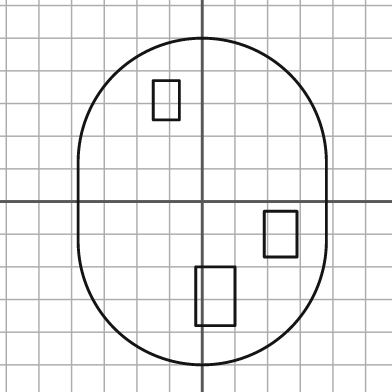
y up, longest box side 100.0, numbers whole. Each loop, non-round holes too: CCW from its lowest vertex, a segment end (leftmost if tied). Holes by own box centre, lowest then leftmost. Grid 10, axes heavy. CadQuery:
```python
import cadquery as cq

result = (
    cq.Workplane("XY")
    .moveTo(-38.0, -12.0)
    .threePointArc((0.0, -50.0), (38.0, -12.0))
    .lineTo(38.0, 12.0)
    .threePointArc((0.0, 50.0), (-38.0, 12.0))
    .close()
    .moveTo(-2.0, -38.0)
    .lineTo(10.0, -38.0)
    .lineTo(10.0, -20.0)
    .lineTo(-2.0, -20.0)
    .close()
    .moveTo(19.0, -17.0)
    .lineTo(29.0, -17.0)
    .lineTo(29.0, -3.0)
    .lineTo(19.0, -3.0)
    .close()
    .moveTo(-15.0, 25.0)
    .lineTo(-7.0, 25.0)
    .lineTo(-7.0, 37.0)
    .lineTo(-15.0, 37.0)
    .close()
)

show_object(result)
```